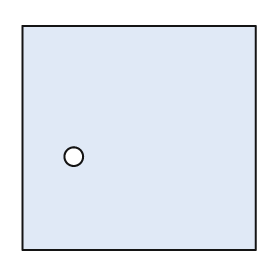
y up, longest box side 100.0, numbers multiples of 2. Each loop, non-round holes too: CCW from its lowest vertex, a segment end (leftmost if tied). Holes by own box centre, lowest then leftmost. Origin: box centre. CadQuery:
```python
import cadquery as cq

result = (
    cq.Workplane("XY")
    .moveTo(-50.0, -48.0)
    .lineTo(50.0, -48.0)
    .lineTo(50.0, 48.0)
    .lineTo(-50.0, 48.0)
    .close()
    .moveTo(-28.0, -8.0)
    .circle(4.0)
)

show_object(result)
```